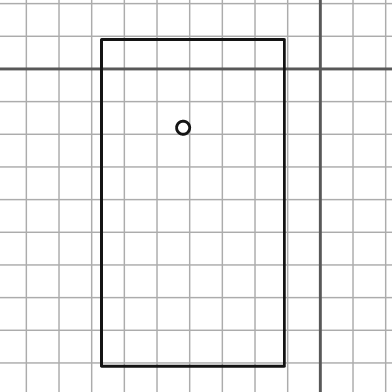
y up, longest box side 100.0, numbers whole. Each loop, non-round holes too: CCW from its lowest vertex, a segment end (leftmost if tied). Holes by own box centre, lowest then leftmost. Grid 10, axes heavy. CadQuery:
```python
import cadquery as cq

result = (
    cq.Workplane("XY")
    .moveTo(-67.0, -91.0)
    .lineTo(-11.0, -91.0)
    .lineTo(-11.0, 9.0)
    .lineTo(-67.0, 9.0)
    .close()
    .moveTo(-42.0, -18.0)
    .circle(2.0)
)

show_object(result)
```